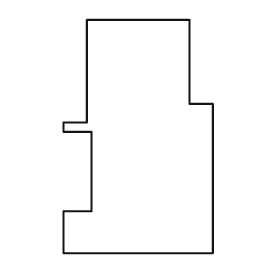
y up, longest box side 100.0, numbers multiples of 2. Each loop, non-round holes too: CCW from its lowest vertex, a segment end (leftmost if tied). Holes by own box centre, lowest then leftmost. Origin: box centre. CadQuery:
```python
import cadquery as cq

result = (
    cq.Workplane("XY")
    .moveTo(-32.0, -50.0)
    .lineTo(32.0, -50.0)
    .lineTo(32.0, 14.0)
    .lineTo(22.0, 14.0)
    .lineTo(22.0, 50.0)
    .lineTo(-22.0, 50.0)
    .lineTo(-22.0, 6.0)
    .lineTo(-32.0, 6.0)
    .lineTo(-32.0, 2.0)
    .lineTo(-20.0, 2.0)
    .lineTo(-20.0, -32.0)
    .lineTo(-32.0, -32.0)
    .close()
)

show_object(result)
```